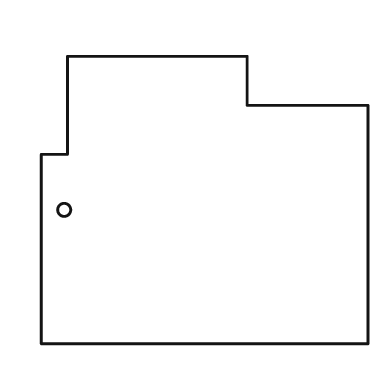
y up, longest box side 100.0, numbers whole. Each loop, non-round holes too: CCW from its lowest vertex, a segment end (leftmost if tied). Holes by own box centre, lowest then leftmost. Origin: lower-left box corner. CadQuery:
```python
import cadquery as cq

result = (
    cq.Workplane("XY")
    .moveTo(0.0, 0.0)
    .lineTo(100.0, 0.0)
    .lineTo(100.0, 73.0)
    .lineTo(63.0, 73.0)
    .lineTo(63.0, 88.0)
    .lineTo(8.0, 88.0)
    .lineTo(8.0, 58.0)
    .lineTo(0.0, 58.0)
    .close()
    .moveTo(7.0, 41.0)
    .circle(2.0)
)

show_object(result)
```